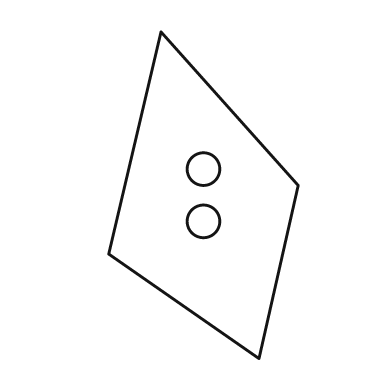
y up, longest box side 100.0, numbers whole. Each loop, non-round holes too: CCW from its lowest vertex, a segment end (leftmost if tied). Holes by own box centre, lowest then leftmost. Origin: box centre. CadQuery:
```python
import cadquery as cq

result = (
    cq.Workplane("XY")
    .moveTo(17.0, -50.0)
    .lineTo(29.0, 3.0)
    .lineTo(-13.0, 50.0)
    .lineTo(-29.0, -18.0)
    .close()
    .moveTo(0.0, -8.0)
    .circle(5.0)
    .moveTo(0.0, 8.0)
    .circle(5.0)
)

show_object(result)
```